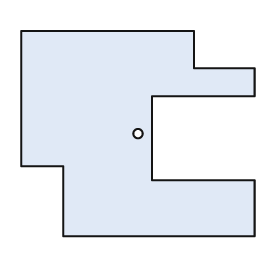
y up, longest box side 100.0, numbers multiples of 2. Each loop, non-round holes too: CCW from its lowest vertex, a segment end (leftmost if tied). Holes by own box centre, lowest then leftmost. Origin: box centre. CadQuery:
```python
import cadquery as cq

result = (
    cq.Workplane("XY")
    .moveTo(-32.0, -44.0)
    .lineTo(50.0, -44.0)
    .lineTo(50.0, -20.0)
    .lineTo(6.0, -20.0)
    .lineTo(6.0, 16.0)
    .lineTo(50.0, 16.0)
    .lineTo(50.0, 28.0)
    .lineTo(24.0, 28.0)
    .lineTo(24.0, 44.0)
    .lineTo(-50.0, 44.0)
    .lineTo(-50.0, -14.0)
    .lineTo(-32.0, -14.0)
    .close()
    .moveTo(0.0, 0.0)
    .circle(2.0)
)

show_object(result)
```